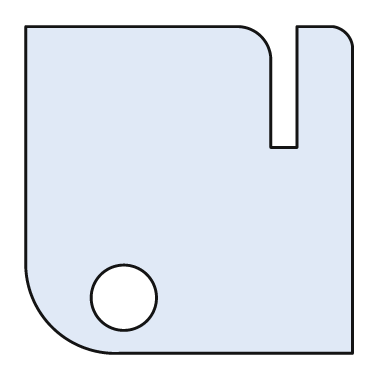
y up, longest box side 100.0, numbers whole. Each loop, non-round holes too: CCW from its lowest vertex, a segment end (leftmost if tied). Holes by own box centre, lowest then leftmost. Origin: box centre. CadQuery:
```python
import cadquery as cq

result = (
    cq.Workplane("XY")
    .moveTo(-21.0, -50.0)
    .lineTo(50.0, -50.0)
    .lineTo(50.0, 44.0)
    .threePointArc((48.0, 48.0), (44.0, 50.0))
    .lineTo(33.0, 50.0)
    .lineTo(33.0, 13.0)
    .lineTo(25.0, 13.0)
    .lineTo(25.0, 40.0)
    .threePointArc((22.0, 47.0), (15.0, 50.0))
    .lineTo(-50.0, 50.0)
    .lineTo(-50.0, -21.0)
    .threePointArc((-42.0, -42.0), (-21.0, -50.0))
    .close()
    .moveTo(-20.0, -33.0)
    .circle(10.0)
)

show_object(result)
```